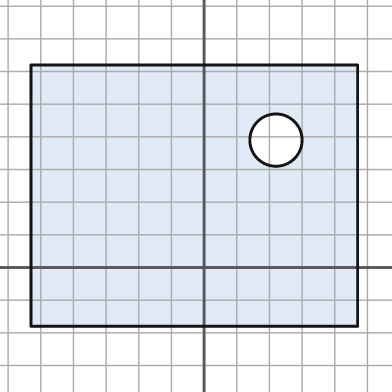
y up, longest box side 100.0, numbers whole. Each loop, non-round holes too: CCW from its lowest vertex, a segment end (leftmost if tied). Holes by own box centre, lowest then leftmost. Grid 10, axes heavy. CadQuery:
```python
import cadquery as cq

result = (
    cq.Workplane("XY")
    .moveTo(-53.0, -18.0)
    .lineTo(47.0, -18.0)
    .lineTo(47.0, 62.0)
    .lineTo(-53.0, 62.0)
    .close()
    .moveTo(22.0, 39.0)
    .circle(8.0)
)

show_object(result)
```